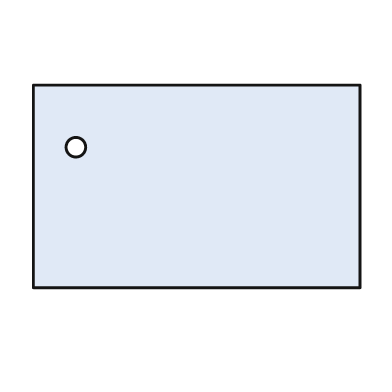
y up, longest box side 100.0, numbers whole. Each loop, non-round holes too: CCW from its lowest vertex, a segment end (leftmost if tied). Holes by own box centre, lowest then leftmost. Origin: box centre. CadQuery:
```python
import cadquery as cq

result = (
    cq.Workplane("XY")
    .moveTo(-50.0, -31.0)
    .lineTo(50.0, -31.0)
    .lineTo(50.0, 31.0)
    .lineTo(-50.0, 31.0)
    .close()
    .moveTo(-37.0, 12.0)
    .circle(3.0)
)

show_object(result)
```